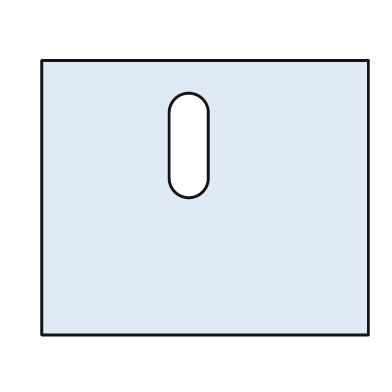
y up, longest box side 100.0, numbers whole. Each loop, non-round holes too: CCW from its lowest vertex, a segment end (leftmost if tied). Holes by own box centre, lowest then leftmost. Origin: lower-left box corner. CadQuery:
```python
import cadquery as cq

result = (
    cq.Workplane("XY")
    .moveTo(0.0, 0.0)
    .lineTo(100.0, 0.0)
    .lineTo(100.0, 84.0)
    .lineTo(0.0, 84.0)
    .close()
    .moveTo(39.0, 48.0)
    .threePointArc((45.0, 42.0), (51.0, 48.0))
    .lineTo(51.0, 68.0)
    .threePointArc((45.0, 74.0), (39.0, 68.0))
    .close()
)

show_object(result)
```